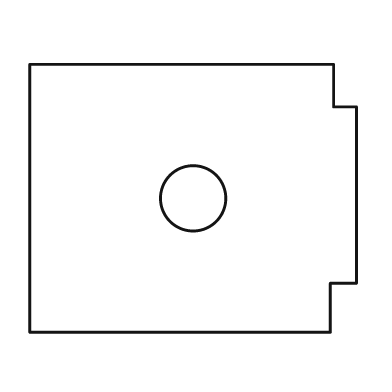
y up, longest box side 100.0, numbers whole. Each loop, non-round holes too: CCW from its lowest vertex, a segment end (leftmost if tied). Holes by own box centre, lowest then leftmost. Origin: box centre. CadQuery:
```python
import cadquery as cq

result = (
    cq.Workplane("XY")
    .moveTo(-50.0, -41.0)
    .lineTo(42.0, -41.0)
    .lineTo(42.0, -26.0)
    .lineTo(50.0, -26.0)
    .lineTo(50.0, 28.0)
    .lineTo(43.0, 28.0)
    .lineTo(43.0, 41.0)
    .lineTo(-50.0, 41.0)
    .close()
    .moveTo(0.0, 0.0)
    .circle(10.0)
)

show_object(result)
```